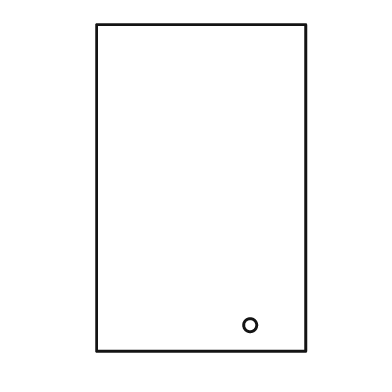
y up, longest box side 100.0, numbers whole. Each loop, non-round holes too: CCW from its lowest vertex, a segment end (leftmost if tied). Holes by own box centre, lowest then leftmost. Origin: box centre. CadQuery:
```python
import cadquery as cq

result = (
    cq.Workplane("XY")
    .moveTo(-32.0, -50.0)
    .lineTo(32.0, -50.0)
    .lineTo(32.0, 50.0)
    .lineTo(-32.0, 50.0)
    .close()
    .moveTo(15.0, -42.0)
    .circle(2.0)
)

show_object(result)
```